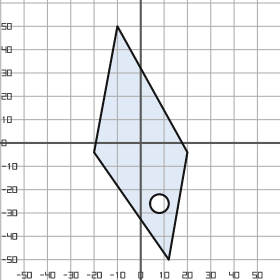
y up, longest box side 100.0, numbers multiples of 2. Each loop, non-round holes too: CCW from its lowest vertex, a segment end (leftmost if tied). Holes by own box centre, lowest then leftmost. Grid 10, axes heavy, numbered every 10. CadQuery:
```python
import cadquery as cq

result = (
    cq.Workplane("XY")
    .moveTo(12.0, -50.0)
    .lineTo(20.0, -4.0)
    .lineTo(-10.0, 50.0)
    .lineTo(-20.0, -4.0)
    .close()
    .moveTo(8.0, -26.0)
    .circle(4.0)
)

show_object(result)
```